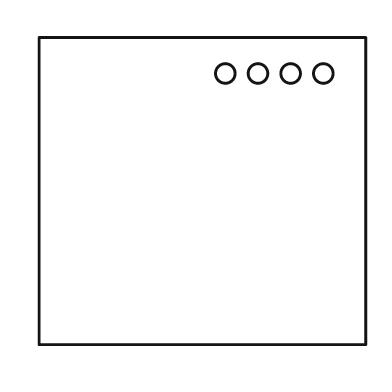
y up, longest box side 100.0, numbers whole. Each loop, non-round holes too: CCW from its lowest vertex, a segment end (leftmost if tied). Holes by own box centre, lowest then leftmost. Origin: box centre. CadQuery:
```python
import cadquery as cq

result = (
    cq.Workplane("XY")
    .moveTo(-50.0, -47.0)
    .lineTo(50.0, -47.0)
    .lineTo(50.0, 47.0)
    .lineTo(-50.0, 47.0)
    .close()
    .moveTo(7.0, 36.0)
    .circle(3.0)
    .moveTo(17.0, 36.0)
    .circle(3.0)
    .moveTo(27.0, 36.0)
    .circle(3.0)
    .moveTo(37.0, 36.0)
    .circle(3.0)
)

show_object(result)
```